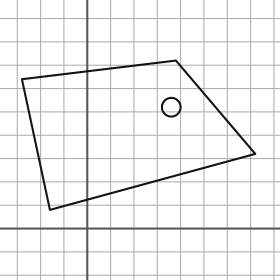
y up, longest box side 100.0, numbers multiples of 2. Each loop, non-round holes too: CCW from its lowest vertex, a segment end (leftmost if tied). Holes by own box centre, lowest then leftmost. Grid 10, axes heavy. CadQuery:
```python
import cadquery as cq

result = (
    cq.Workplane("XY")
    .moveTo(-16.0, 8.0)
    .lineTo(72.0, 32.0)
    .lineTo(38.0, 72.0)
    .lineTo(-28.0, 64.0)
    .close()
    .moveTo(36.0, 52.0)
    .circle(4.0)
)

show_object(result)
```